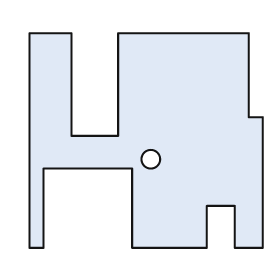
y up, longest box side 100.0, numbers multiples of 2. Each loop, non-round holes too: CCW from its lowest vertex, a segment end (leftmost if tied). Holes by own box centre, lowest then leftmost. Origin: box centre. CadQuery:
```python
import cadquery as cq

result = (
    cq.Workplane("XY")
    .moveTo(-50.0, -46.0)
    .lineTo(-44.0, -46.0)
    .lineTo(-44.0, -12.0)
    .lineTo(-6.0, -12.0)
    .lineTo(-6.0, -46.0)
    .lineTo(26.0, -46.0)
    .lineTo(26.0, -28.0)
    .lineTo(38.0, -28.0)
    .lineTo(38.0, -46.0)
    .lineTo(50.0, -46.0)
    .lineTo(50.0, 10.0)
    .lineTo(44.0, 10.0)
    .lineTo(44.0, 46.0)
    .lineTo(-12.0, 46.0)
    .lineTo(-12.0, 2.0)
    .lineTo(-32.0, 2.0)
    .lineTo(-32.0, 46.0)
    .lineTo(-50.0, 46.0)
    .close()
    .moveTo(2.0, -8.0)
    .circle(4.0)
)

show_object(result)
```